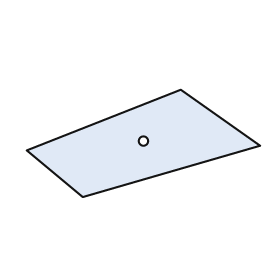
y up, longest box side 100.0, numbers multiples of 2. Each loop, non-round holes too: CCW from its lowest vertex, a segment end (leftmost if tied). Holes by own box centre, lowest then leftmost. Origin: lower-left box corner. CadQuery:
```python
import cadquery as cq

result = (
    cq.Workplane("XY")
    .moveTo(24.0, 0.0)
    .lineTo(100.0, 22.0)
    .lineTo(66.0, 46.0)
    .lineTo(0.0, 20.0)
    .close()
    .moveTo(50.0, 24.0)
    .circle(2.0)
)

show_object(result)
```